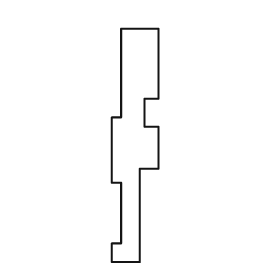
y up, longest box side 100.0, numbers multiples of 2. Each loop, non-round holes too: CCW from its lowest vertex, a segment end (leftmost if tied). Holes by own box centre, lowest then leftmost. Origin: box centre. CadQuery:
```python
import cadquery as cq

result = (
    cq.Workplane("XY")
    .moveTo(-10.0, -50.0)
    .lineTo(2.0, -50.0)
    .lineTo(2.0, -10.0)
    .lineTo(10.0, -10.0)
    .lineTo(10.0, 8.0)
    .lineTo(4.0, 8.0)
    .lineTo(4.0, 20.0)
    .lineTo(10.0, 20.0)
    .lineTo(10.0, 50.0)
    .lineTo(-6.0, 50.0)
    .lineTo(-6.0, 12.0)
    .lineTo(-10.0, 12.0)
    .lineTo(-10.0, -16.0)
    .lineTo(-6.0, -16.0)
    .lineTo(-6.0, -42.0)
    .lineTo(-10.0, -42.0)
    .close()
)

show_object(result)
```